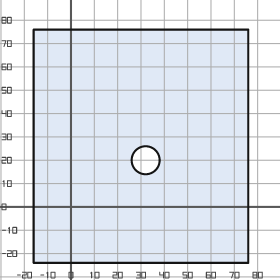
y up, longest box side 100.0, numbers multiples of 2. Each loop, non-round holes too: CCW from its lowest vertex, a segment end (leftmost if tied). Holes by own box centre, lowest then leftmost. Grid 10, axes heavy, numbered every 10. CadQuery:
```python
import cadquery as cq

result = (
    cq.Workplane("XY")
    .moveTo(-16.0, -24.0)
    .lineTo(76.0, -24.0)
    .lineTo(76.0, 76.0)
    .lineTo(-16.0, 76.0)
    .close()
    .moveTo(32.0, 20.0)
    .circle(6.0)
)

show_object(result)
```